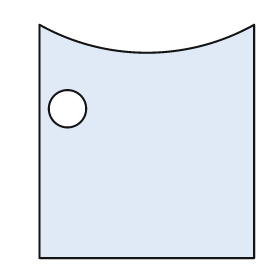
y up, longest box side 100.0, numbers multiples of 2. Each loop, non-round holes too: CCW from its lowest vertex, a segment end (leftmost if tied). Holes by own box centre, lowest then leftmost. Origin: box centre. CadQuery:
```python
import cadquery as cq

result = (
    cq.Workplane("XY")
    .moveTo(-46.0, -50.0)
    .lineTo(46.0, -50.0)
    .lineTo(46.0, 50.0)
    .threePointArc((0.0, 38.0), (-46.0, 50.0))
    .close()
    .moveTo(-34.0, 14.0)
    .circle(8.0)
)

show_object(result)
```